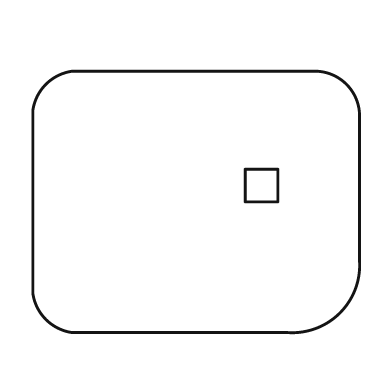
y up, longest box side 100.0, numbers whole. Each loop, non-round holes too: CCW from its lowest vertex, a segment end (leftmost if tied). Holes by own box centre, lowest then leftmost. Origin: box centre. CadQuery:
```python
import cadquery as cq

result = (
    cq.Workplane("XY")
    .moveTo(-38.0, -40.0)
    .lineTo(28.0, -40.0)
    .threePointArc((44.0, -34.0), (50.0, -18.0))
    .lineTo(50.0, 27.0)
    .threePointArc((46.0, 36.0), (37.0, 40.0))
    .lineTo(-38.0, 40.0)
    .threePointArc((-46.0, 36.0), (-50.0, 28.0))
    .lineTo(-50.0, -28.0)
    .threePointArc((-46.0, -36.0), (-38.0, -40.0))
    .close()
    .moveTo(15.0, 0.0)
    .lineTo(25.0, 0.0)
    .lineTo(25.0, 10.0)
    .lineTo(15.0, 10.0)
    .close()
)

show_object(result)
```